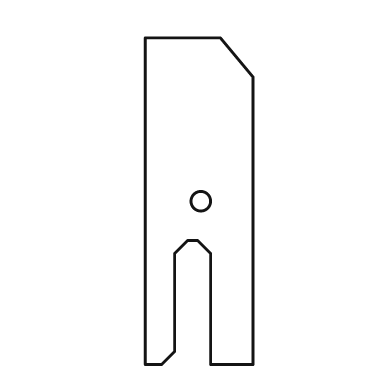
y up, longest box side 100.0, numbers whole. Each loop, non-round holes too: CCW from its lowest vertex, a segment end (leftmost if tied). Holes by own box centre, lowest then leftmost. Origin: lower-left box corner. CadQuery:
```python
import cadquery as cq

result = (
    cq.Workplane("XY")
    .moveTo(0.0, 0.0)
    .lineTo(5.0, 0.0)
    .lineTo(9.0, 4.0)
    .lineTo(9.0, 34.0)
    .lineTo(13.0, 38.0)
    .lineTo(16.0, 38.0)
    .lineTo(20.0, 34.0)
    .lineTo(20.0, 0.0)
    .lineTo(33.0, 0.0)
    .lineTo(33.0, 88.0)
    .lineTo(23.0, 100.0)
    .lineTo(0.0, 100.0)
    .close()
    .moveTo(17.0, 50.0)
    .circle(3.0)
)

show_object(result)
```